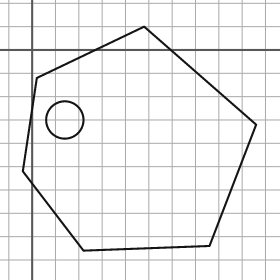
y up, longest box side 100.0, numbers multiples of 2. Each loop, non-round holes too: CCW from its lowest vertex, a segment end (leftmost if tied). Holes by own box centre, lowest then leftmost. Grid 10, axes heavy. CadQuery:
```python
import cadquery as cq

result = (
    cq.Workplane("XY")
    .moveTo(22.0, -86.0)
    .lineTo(76.0, -84.0)
    .lineTo(96.0, -32.0)
    .lineTo(48.0, 10.0)
    .lineTo(2.0, -12.0)
    .lineTo(-4.0, -52.0)
    .close()
    .moveTo(14.0, -30.0)
    .circle(8.0)
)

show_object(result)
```